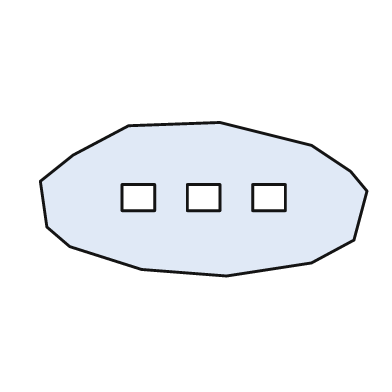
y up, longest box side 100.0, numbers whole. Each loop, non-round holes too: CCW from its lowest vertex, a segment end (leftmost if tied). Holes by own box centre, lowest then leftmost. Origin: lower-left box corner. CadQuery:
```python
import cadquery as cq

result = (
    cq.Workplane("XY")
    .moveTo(57.0, 0.0)
    .lineTo(83.0, 4.0)
    .lineTo(96.0, 11.0)
    .lineTo(100.0, 26.0)
    .lineTo(95.0, 32.0)
    .lineTo(83.0, 40.0)
    .lineTo(55.0, 47.0)
    .lineTo(27.0, 46.0)
    .lineTo(10.0, 37.0)
    .lineTo(0.0, 29.0)
    .lineTo(2.0, 15.0)
    .lineTo(9.0, 9.0)
    .lineTo(31.0, 2.0)
    .close()
    .moveTo(25.0, 20.0)
    .lineTo(35.0, 20.0)
    .lineTo(35.0, 28.0)
    .lineTo(25.0, 28.0)
    .close()
    .moveTo(45.0, 20.0)
    .lineTo(55.0, 20.0)
    .lineTo(55.0, 28.0)
    .lineTo(45.0, 28.0)
    .close()
    .moveTo(65.0, 20.0)
    .lineTo(75.0, 20.0)
    .lineTo(75.0, 28.0)
    .lineTo(65.0, 28.0)
    .close()
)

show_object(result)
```